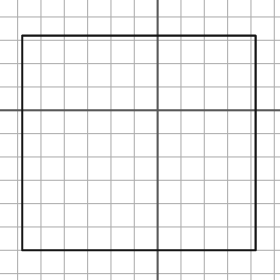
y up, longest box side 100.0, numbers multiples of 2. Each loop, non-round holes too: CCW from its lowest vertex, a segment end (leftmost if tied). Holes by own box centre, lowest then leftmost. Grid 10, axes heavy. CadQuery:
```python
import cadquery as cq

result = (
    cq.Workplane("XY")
    .moveTo(-58.0, -60.0)
    .lineTo(42.0, -60.0)
    .lineTo(42.0, 32.0)
    .lineTo(-58.0, 32.0)
    .close()
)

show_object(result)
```